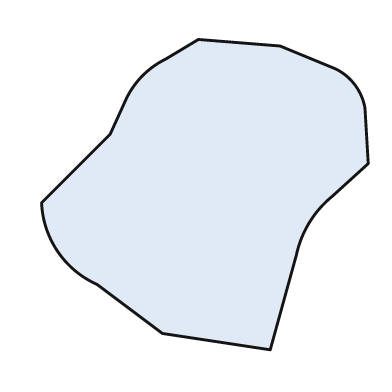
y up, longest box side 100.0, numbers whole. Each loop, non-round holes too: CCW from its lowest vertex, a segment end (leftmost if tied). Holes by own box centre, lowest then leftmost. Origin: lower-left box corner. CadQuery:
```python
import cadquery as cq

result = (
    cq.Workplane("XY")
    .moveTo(70.0, 0.0)
    .lineTo(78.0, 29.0)
    .threePointArc((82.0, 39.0), (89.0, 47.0))
    .lineTo(100.0, 57.0)
    .lineTo(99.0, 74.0)
    .threePointArc((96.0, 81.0), (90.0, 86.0))
    .lineTo(73.0, 93.0)
    .lineTo(48.0, 95.0)
    .lineTo(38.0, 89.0)
    .threePointArc((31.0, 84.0), (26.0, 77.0))
    .lineTo(21.0, 66.0)
    .lineTo(0.0, 45.0)
    .threePointArc((5.0, 30.0), (17.0, 20.0))
    .lineTo(37.0, 5.0)
    .close()
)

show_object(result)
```